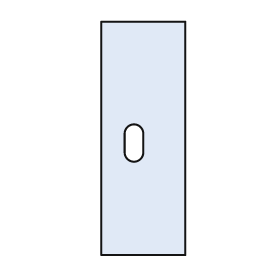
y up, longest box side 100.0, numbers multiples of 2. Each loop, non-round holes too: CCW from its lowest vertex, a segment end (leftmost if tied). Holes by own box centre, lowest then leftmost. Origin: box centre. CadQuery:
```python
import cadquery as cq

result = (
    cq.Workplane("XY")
    .moveTo(-18.0, -50.0)
    .lineTo(18.0, -50.0)
    .lineTo(18.0, 50.0)
    .lineTo(-18.0, 50.0)
    .close()
    .moveTo(-8.0, -6.0)
    .threePointArc((-4.0, -10.0), (0.0, -6.0))
    .lineTo(0.0, 2.0)
    .threePointArc((-4.0, 6.0), (-8.0, 2.0))
    .close()
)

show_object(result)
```